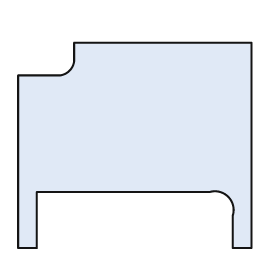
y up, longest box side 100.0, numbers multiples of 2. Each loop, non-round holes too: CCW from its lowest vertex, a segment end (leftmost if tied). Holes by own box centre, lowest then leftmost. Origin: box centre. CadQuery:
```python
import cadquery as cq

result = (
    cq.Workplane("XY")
    .moveTo(-50.0, -44.0)
    .lineTo(-42.0, -44.0)
    .lineTo(-42.0, -20.0)
    .lineTo(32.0, -20.0)
    .threePointArc((40.0, -22.0), (42.0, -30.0))
    .lineTo(42.0, -44.0)
    .lineTo(50.0, -44.0)
    .lineTo(50.0, 44.0)
    .lineTo(-26.0, 44.0)
    .lineTo(-26.0, 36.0)
    .threePointArc((-28.0, 32.0), (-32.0, 30.0))
    .lineTo(-50.0, 30.0)
    .close()
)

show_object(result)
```